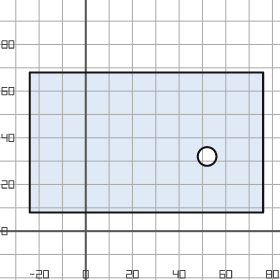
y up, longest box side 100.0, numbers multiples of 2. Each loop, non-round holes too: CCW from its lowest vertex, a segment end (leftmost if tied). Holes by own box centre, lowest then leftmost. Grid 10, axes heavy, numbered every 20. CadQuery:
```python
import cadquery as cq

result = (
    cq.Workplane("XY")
    .moveTo(-24.0, 8.0)
    .lineTo(76.0, 8.0)
    .lineTo(76.0, 68.0)
    .lineTo(-24.0, 68.0)
    .close()
    .moveTo(52.0, 32.0)
    .circle(4.0)
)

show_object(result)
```